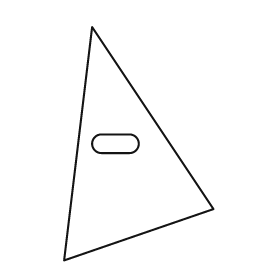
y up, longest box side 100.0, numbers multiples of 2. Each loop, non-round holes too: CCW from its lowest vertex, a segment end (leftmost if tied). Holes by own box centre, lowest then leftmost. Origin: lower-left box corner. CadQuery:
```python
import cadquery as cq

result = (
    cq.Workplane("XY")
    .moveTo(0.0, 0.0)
    .lineTo(64.0, 22.0)
    .lineTo(12.0, 100.0)
    .close()
    .moveTo(16.0, 46.0)
    .lineTo(28.0, 46.0)
    .threePointArc((32.0, 50.0), (28.0, 54.0))
    .lineTo(16.0, 54.0)
    .threePointArc((12.0, 50.0), (16.0, 46.0))
    .close()
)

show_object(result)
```